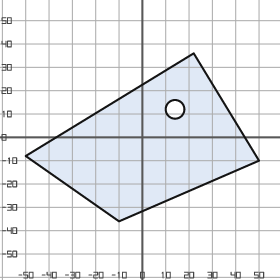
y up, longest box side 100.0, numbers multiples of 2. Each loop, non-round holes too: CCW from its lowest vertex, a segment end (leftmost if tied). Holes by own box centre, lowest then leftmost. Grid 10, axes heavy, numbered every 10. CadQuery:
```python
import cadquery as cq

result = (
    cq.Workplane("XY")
    .moveTo(-10.0, -36.0)
    .lineTo(50.0, -10.0)
    .lineTo(22.0, 36.0)
    .lineTo(-50.0, -8.0)
    .close()
    .moveTo(14.0, 12.0)
    .circle(4.0)
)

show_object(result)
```